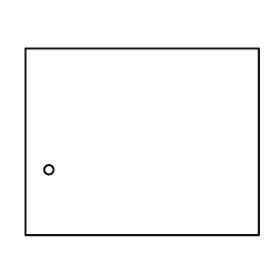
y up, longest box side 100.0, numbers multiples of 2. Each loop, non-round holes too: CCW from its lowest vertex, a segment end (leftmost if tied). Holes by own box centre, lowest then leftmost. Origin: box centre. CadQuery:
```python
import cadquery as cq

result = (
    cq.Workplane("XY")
    .moveTo(-50.0, -40.0)
    .lineTo(50.0, -40.0)
    .lineTo(50.0, 40.0)
    .lineTo(-50.0, 40.0)
    .close()
    .moveTo(-40.0, -12.0)
    .circle(2.0)
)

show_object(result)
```